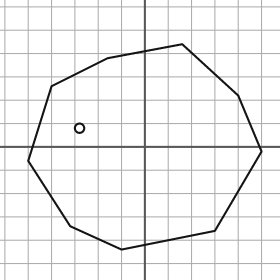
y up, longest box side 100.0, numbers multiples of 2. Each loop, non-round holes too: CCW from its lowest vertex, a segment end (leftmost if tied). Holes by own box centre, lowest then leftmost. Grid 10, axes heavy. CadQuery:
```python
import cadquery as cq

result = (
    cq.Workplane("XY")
    .moveTo(-10.0, -44.0)
    .lineTo(30.0, -36.0)
    .lineTo(50.0, -2.0)
    .lineTo(40.0, 22.0)
    .lineTo(16.0, 44.0)
    .lineTo(-16.0, 38.0)
    .lineTo(-40.0, 26.0)
    .lineTo(-50.0, -6.0)
    .lineTo(-32.0, -34.0)
    .close()
    .moveTo(-28.0, 8.0)
    .circle(2.0)
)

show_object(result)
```